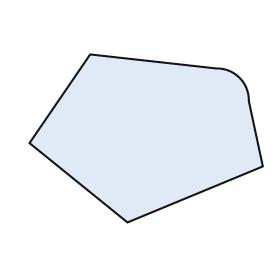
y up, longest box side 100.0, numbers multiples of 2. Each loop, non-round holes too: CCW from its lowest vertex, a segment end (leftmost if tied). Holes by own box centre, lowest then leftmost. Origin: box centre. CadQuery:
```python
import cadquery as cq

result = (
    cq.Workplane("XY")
    .moveTo(-8.0, -36.0)
    .lineTo(50.0, -12.0)
    .lineTo(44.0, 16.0)
    .threePointArc((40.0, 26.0), (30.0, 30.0))
    .lineTo(-24.0, 36.0)
    .lineTo(-50.0, -2.0)
    .close()
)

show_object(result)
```